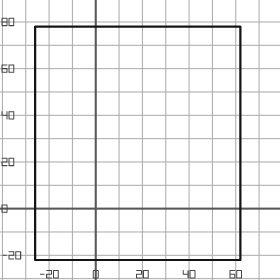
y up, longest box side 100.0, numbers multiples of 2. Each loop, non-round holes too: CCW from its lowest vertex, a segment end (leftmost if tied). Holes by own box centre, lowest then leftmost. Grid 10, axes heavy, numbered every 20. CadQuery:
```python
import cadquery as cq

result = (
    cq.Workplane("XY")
    .moveTo(-26.0, -22.0)
    .lineTo(62.0, -22.0)
    .lineTo(62.0, 78.0)
    .lineTo(-26.0, 78.0)
    .close()
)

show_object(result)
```